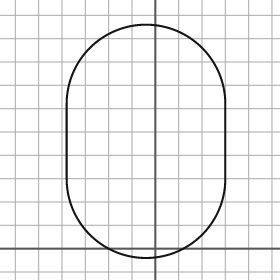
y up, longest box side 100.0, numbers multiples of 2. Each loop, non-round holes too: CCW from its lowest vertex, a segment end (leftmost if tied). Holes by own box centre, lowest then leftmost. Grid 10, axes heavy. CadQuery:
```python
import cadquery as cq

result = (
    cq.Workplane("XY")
    .moveTo(-38.0, 30.0)
    .threePointArc((-4.0, -4.0), (30.0, 30.0))
    .lineTo(30.0, 62.0)
    .threePointArc((-4.0, 96.0), (-38.0, 62.0))
    .close()
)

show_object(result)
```